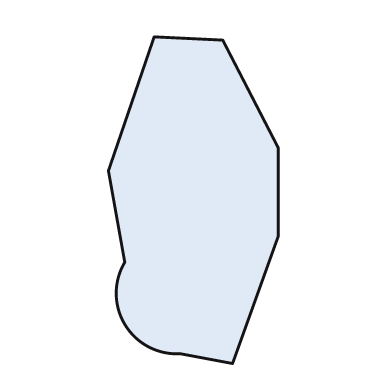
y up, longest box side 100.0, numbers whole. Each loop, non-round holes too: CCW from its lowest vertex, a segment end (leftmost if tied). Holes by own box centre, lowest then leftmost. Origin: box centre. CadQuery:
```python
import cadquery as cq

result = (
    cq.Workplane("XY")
    .moveTo(12.0, -50.0)
    .lineTo(26.0, -11.0)
    .lineTo(26.0, 16.0)
    .lineTo(9.0, 49.0)
    .lineTo(-12.0, 50.0)
    .lineTo(-26.0, 9.0)
    .lineTo(-21.0, -19.0)
    .threePointArc((-21.0, -38.0), (-4.0, -47.0))
    .close()
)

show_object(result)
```